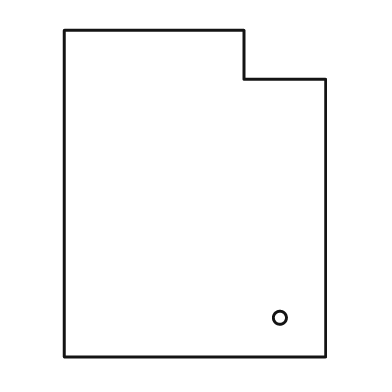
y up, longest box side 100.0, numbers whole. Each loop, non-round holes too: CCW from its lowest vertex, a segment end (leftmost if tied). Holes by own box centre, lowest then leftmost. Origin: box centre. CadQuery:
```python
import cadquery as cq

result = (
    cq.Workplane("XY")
    .moveTo(-40.0, -50.0)
    .lineTo(40.0, -50.0)
    .lineTo(40.0, 35.0)
    .lineTo(15.0, 35.0)
    .lineTo(15.0, 50.0)
    .lineTo(-40.0, 50.0)
    .close()
    .moveTo(26.0, -38.0)
    .circle(2.0)
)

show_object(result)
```